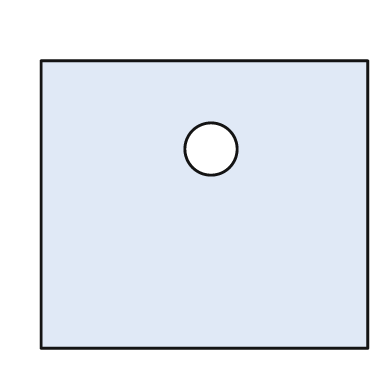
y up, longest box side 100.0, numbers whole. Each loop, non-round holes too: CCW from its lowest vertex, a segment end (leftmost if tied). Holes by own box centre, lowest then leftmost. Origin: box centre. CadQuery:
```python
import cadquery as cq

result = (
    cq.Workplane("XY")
    .moveTo(-50.0, -44.0)
    .lineTo(50.0, -44.0)
    .lineTo(50.0, 44.0)
    .lineTo(-50.0, 44.0)
    .close()
    .moveTo(2.0, 17.0)
    .circle(8.0)
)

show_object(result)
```